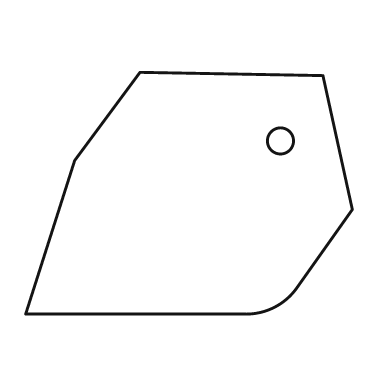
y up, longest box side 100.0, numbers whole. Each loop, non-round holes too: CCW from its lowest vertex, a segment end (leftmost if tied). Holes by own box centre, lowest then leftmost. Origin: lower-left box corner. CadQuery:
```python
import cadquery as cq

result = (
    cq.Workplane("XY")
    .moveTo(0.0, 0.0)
    .lineTo(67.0, 0.0)
    .threePointArc((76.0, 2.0), (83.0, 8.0))
    .lineTo(100.0, 32.0)
    .lineTo(91.0, 73.0)
    .lineTo(35.0, 74.0)
    .lineTo(15.0, 47.0)
    .close()
    .moveTo(78.0, 53.0)
    .circle(4.0)
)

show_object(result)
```